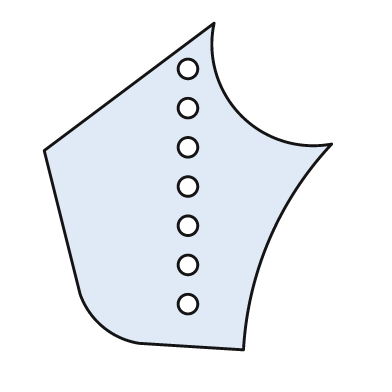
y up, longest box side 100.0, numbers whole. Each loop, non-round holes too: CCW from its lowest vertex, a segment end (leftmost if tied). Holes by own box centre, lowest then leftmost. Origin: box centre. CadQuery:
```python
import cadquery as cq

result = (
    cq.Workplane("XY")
    .moveTo(17.0, -50.0)
    .threePointArc((25.0, -16.0), (44.0, 13.0))
    .threePointArc((16.0, 22.0), (8.0, 50.0))
    .lineTo(-44.0, 11.0)
    .lineTo(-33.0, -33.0)
    .threePointArc((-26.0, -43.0), (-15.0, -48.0))
    .close()
    .moveTo(0.0, -36.0)
    .circle(3.0)
    .moveTo(0.0, -24.0)
    .circle(3.0)
    .moveTo(0.0, -12.0)
    .circle(3.0)
    .moveTo(0.0, 0.0)
    .circle(3.0)
    .moveTo(0.0, 12.0)
    .circle(3.0)
    .moveTo(0.0, 24.0)
    .circle(3.0)
    .moveTo(0.0, 36.0)
    .circle(3.0)
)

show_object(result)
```